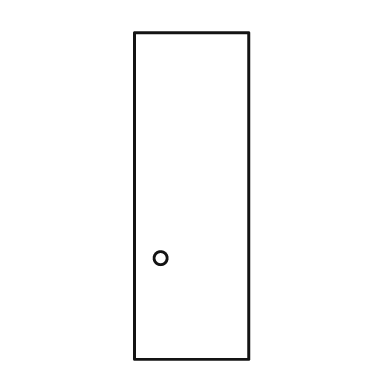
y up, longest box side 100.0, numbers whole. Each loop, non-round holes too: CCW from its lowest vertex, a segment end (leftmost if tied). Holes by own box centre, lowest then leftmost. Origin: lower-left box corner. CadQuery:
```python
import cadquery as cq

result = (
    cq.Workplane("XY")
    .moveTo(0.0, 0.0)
    .lineTo(35.0, 0.0)
    .lineTo(35.0, 100.0)
    .lineTo(0.0, 100.0)
    .close()
    .moveTo(8.0, 31.0)
    .circle(2.0)
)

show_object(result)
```